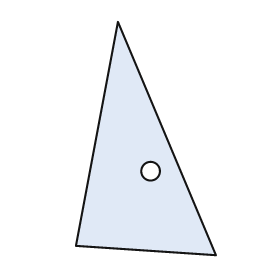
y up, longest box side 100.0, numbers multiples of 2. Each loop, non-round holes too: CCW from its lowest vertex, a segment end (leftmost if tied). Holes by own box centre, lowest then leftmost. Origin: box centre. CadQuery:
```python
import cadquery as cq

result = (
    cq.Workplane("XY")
    .moveTo(30.0, -50.0)
    .lineTo(-12.0, 50.0)
    .lineTo(-30.0, -46.0)
    .close()
    .moveTo(2.0, -14.0)
    .circle(4.0)
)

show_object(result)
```